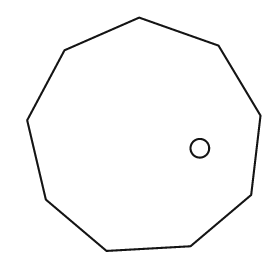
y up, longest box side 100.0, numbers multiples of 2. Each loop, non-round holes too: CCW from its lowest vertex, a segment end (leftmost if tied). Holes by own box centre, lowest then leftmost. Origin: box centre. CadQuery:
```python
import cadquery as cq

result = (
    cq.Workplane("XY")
    .moveTo(-16.0, -50.0)
    .lineTo(20.0, -48.0)
    .lineTo(46.0, -26.0)
    .lineTo(50.0, 8.0)
    .lineTo(32.0, 38.0)
    .lineTo(-2.0, 50.0)
    .lineTo(-34.0, 36.0)
    .lineTo(-50.0, 6.0)
    .lineTo(-42.0, -28.0)
    .close()
    .moveTo(24.0, -6.0)
    .circle(4.0)
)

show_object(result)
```